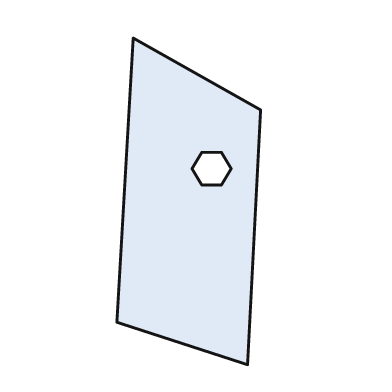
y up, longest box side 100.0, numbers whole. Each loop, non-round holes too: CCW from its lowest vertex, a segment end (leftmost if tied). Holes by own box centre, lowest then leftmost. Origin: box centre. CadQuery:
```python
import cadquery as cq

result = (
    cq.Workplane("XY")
    .moveTo(18.0, -50.0)
    .lineTo(22.0, 28.0)
    .lineTo(-17.0, 50.0)
    .lineTo(-22.0, -37.0)
    .close()
    .moveTo(4.0, 5.0)
    .lineTo(10.0, 5.0)
    .lineTo(13.0, 10.0)
    .lineTo(10.0, 15.0)
    .lineTo(4.0, 15.0)
    .lineTo(1.0, 10.0)
    .close()
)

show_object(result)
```